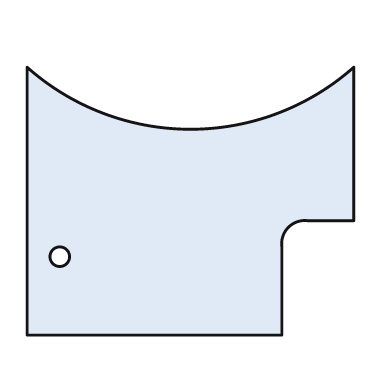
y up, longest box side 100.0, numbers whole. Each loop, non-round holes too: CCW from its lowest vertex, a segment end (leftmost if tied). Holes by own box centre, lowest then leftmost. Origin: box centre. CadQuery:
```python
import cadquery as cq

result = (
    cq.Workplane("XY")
    .moveTo(-50.0, -41.0)
    .lineTo(28.0, -41.0)
    .lineTo(28.0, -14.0)
    .threePointArc((30.0, -8.0), (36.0, -6.0))
    .lineTo(50.0, -6.0)
    .lineTo(50.0, 41.0)
    .threePointArc((0.0, 22.0), (-50.0, 41.0))
    .close()
    .moveTo(-40.0, -17.0)
    .circle(3.0)
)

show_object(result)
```